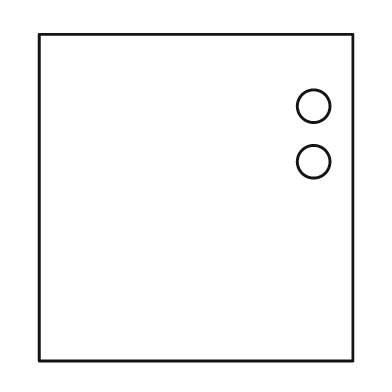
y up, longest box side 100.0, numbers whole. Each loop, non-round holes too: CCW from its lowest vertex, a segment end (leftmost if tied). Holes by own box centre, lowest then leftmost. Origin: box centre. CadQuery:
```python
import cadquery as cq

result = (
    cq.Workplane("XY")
    .moveTo(-48.0, -50.0)
    .lineTo(48.0, -50.0)
    .lineTo(48.0, 50.0)
    .lineTo(-48.0, 50.0)
    .close()
    .moveTo(36.0, 11.0)
    .circle(5.0)
    .moveTo(36.0, 28.0)
    .circle(5.0)
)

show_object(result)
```